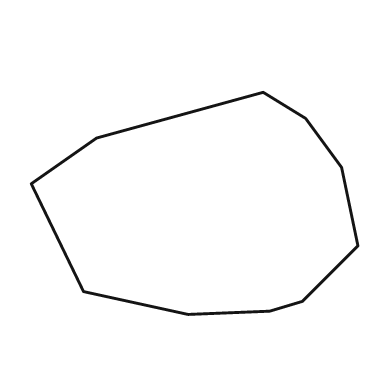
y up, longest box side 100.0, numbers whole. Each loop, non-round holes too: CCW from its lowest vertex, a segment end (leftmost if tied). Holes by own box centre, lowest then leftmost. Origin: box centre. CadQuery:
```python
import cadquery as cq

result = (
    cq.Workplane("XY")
    .moveTo(-2.0, -34.0)
    .lineTo(23.0, -33.0)
    .lineTo(33.0, -30.0)
    .lineTo(50.0, -13.0)
    .lineTo(45.0, 11.0)
    .lineTo(34.0, 26.0)
    .lineTo(21.0, 34.0)
    .lineTo(-30.0, 20.0)
    .lineTo(-50.0, 6.0)
    .lineTo(-34.0, -27.0)
    .close()
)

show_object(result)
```